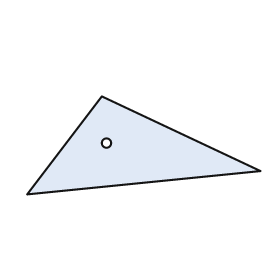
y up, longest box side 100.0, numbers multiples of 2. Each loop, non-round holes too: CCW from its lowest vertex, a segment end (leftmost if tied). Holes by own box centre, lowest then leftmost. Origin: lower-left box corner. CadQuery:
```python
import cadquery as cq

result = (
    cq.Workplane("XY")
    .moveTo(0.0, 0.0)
    .lineTo(100.0, 10.0)
    .lineTo(32.0, 42.0)
    .close()
    .moveTo(34.0, 22.0)
    .circle(2.0)
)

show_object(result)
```